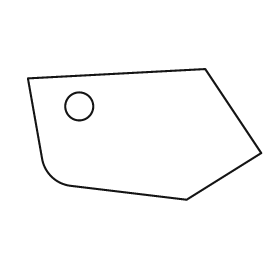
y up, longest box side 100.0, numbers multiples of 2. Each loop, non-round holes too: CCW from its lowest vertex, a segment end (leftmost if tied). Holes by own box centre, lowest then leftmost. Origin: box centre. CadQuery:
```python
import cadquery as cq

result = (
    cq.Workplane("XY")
    .moveTo(18.0, -28.0)
    .lineTo(50.0, -8.0)
    .lineTo(26.0, 28.0)
    .lineTo(-50.0, 24.0)
    .lineTo(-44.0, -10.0)
    .threePointArc((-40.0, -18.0), (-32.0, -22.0))
    .close()
    .moveTo(-28.0, 12.0)
    .circle(6.0)
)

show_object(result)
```